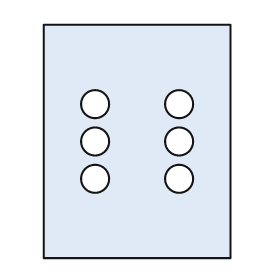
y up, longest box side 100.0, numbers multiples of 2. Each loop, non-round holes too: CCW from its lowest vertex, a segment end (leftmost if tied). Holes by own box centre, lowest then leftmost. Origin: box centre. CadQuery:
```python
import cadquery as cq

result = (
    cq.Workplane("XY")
    .moveTo(-40.0, -50.0)
    .lineTo(40.0, -50.0)
    .lineTo(40.0, 50.0)
    .lineTo(-40.0, 50.0)
    .close()
    .moveTo(-18.0, -16.0)
    .circle(6.0)
    .moveTo(18.0, -16.0)
    .circle(6.0)
    .moveTo(-18.0, 0.0)
    .circle(6.0)
    .moveTo(18.0, 0.0)
    .circle(6.0)
    .moveTo(-18.0, 16.0)
    .circle(6.0)
    .moveTo(18.0, 16.0)
    .circle(6.0)
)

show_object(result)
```